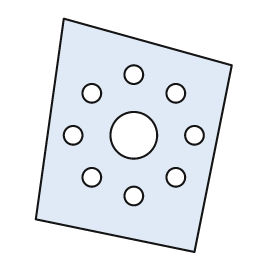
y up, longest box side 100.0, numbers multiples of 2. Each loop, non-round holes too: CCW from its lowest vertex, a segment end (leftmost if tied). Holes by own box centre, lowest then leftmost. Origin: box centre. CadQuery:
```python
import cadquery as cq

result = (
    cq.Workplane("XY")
    .moveTo(26.0, -50.0)
    .lineTo(42.0, 30.0)
    .lineTo(-30.0, 50.0)
    .lineTo(-42.0, -36.0)
    .close()
    .moveTo(0.0, -26.0)
    .circle(4.0)
    .moveTo(-18.0, -18.0)
    .circle(4.0)
    .moveTo(18.0, -18.0)
    .circle(4.0)
    .moveTo(-26.0, 0.0)
    .circle(4.0)
    .moveTo(0.0, 0.0)
    .circle(10.0)
    .moveTo(26.0, 0.0)
    .circle(4.0)
    .moveTo(-18.0, 18.0)
    .circle(4.0)
    .moveTo(18.0, 18.0)
    .circle(4.0)
    .moveTo(0.0, 26.0)
    .circle(4.0)
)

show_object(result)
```